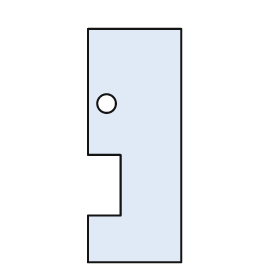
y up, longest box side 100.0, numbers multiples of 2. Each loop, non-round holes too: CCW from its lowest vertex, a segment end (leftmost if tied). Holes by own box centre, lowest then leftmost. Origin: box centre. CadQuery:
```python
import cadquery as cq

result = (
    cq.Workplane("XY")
    .moveTo(-20.0, -50.0)
    .lineTo(20.0, -50.0)
    .lineTo(20.0, 50.0)
    .lineTo(-20.0, 50.0)
    .lineTo(-20.0, -4.0)
    .lineTo(-6.0, -4.0)
    .lineTo(-6.0, -30.0)
    .lineTo(-20.0, -30.0)
    .close()
    .moveTo(-12.0, 18.0)
    .circle(4.0)
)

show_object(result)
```